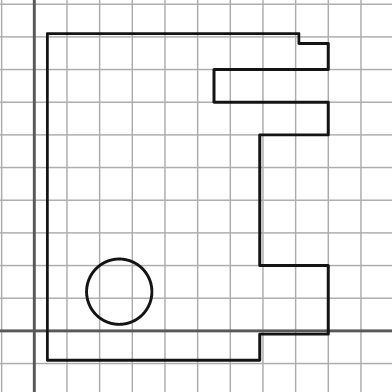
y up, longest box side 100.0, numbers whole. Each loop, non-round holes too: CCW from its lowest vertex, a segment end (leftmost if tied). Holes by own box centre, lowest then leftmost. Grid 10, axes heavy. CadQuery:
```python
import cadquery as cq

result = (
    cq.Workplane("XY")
    .moveTo(4.0, -9.0)
    .lineTo(69.0, -9.0)
    .lineTo(69.0, -1.0)
    .lineTo(90.0, -1.0)
    .lineTo(90.0, 20.0)
    .lineTo(69.0, 20.0)
    .lineTo(69.0, 60.0)
    .lineTo(90.0, 60.0)
    .lineTo(90.0, 70.0)
    .lineTo(55.0, 70.0)
    .lineTo(55.0, 80.0)
    .lineTo(90.0, 80.0)
    .lineTo(90.0, 88.0)
    .lineTo(81.0, 88.0)
    .lineTo(81.0, 91.0)
    .lineTo(4.0, 91.0)
    .close()
    .moveTo(26.0, 12.0)
    .circle(10.0)
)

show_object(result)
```